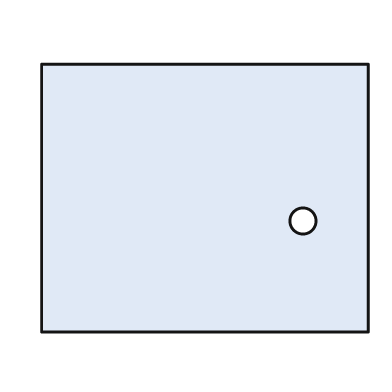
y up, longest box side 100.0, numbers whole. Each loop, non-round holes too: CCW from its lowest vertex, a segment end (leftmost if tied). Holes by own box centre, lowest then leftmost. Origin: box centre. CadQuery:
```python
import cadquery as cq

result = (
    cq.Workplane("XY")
    .moveTo(-50.0, -41.0)
    .lineTo(50.0, -41.0)
    .lineTo(50.0, 41.0)
    .lineTo(-50.0, 41.0)
    .close()
    .moveTo(30.0, -7.0)
    .circle(4.0)
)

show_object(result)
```